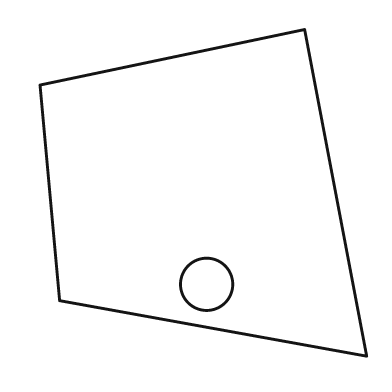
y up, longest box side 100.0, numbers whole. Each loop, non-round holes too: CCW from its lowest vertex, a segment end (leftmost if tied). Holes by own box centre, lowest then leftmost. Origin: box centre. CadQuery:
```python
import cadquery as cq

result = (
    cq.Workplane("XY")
    .moveTo(50.0, -50.0)
    .lineTo(31.0, 50.0)
    .lineTo(-50.0, 33.0)
    .lineTo(-44.0, -33.0)
    .close()
    .moveTo(1.0, -28.0)
    .circle(8.0)
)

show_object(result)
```